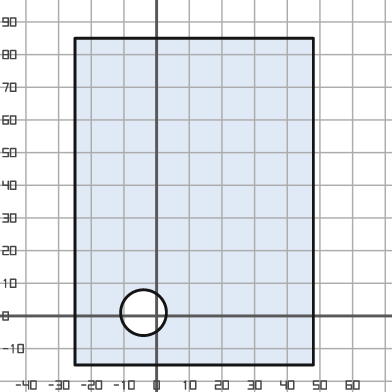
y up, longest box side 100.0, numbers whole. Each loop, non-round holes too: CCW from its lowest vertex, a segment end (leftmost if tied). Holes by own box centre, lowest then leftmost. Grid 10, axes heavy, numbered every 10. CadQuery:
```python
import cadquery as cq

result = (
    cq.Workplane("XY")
    .moveTo(-25.0, -15.0)
    .lineTo(48.0, -15.0)
    .lineTo(48.0, 85.0)
    .lineTo(-25.0, 85.0)
    .close()
    .moveTo(-4.0, 1.0)
    .circle(7.0)
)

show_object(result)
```